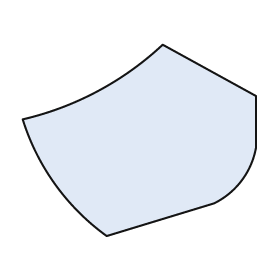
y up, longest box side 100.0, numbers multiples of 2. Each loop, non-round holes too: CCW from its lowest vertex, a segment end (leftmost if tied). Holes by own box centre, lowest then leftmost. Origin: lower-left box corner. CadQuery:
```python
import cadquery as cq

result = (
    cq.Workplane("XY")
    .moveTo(36.0, 0.0)
    .lineTo(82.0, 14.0)
    .threePointArc((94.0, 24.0), (100.0, 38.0))
    .lineTo(100.0, 60.0)
    .lineTo(60.0, 82.0)
    .threePointArc((32.0, 62.0), (0.0, 50.0))
    .threePointArc((14.0, 22.0), (36.0, 0.0))
    .close()
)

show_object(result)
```